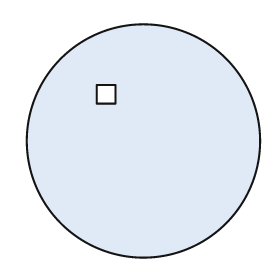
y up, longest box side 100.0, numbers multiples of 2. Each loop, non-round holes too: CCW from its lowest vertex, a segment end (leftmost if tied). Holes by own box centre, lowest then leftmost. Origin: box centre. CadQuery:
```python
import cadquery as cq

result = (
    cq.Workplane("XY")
    .moveTo(0.0, 0.0)
    .circle(50.0)
    .moveTo(-20.0, 16.0)
    .lineTo(-12.0, 16.0)
    .lineTo(-12.0, 24.0)
    .lineTo(-20.0, 24.0)
    .close()
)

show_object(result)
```